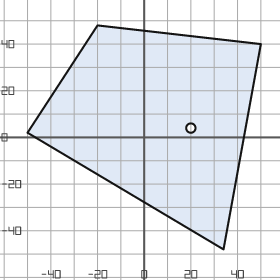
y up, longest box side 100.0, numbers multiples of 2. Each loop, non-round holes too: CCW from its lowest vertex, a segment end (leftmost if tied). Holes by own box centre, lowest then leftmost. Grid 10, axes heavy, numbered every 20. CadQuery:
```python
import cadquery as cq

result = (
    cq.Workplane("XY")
    .moveTo(34.0, -48.0)
    .lineTo(50.0, 40.0)
    .lineTo(-20.0, 48.0)
    .lineTo(-50.0, 2.0)
    .close()
    .moveTo(20.0, 4.0)
    .circle(2.0)
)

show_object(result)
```